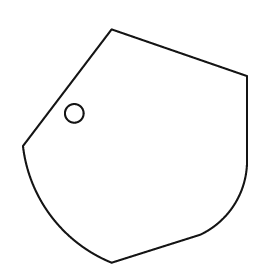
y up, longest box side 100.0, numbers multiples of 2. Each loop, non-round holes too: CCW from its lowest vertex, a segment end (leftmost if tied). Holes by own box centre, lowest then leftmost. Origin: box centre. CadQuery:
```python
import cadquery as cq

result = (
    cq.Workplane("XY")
    .moveTo(-10.0, -50.0)
    .lineTo(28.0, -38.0)
    .threePointArc((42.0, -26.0), (48.0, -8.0))
    .lineTo(48.0, 30.0)
    .lineTo(-10.0, 50.0)
    .lineTo(-48.0, 0.0)
    .threePointArc((-36.0, -30.0), (-10.0, -50.0))
    .close()
    .moveTo(-26.0, 14.0)
    .circle(4.0)
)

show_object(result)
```